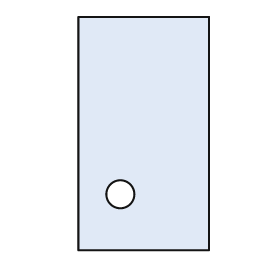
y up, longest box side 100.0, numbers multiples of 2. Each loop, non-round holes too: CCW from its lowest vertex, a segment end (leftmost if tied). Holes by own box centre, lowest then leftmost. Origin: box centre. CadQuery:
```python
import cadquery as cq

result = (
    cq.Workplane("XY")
    .moveTo(-28.0, -50.0)
    .lineTo(28.0, -50.0)
    .lineTo(28.0, 50.0)
    .lineTo(-28.0, 50.0)
    .close()
    .moveTo(-10.0, -26.0)
    .circle(6.0)
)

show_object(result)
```